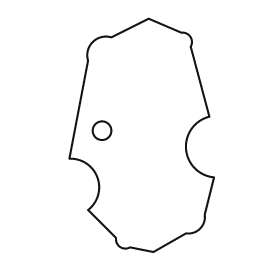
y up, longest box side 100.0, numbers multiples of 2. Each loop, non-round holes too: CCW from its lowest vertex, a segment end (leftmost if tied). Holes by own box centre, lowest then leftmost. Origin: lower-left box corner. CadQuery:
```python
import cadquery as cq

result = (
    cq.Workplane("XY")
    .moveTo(36.0, 0.0)
    .lineTo(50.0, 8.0)
    .threePointArc((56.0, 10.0), (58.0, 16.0))
    .lineTo(62.0, 32.0)
    .threePointArc((50.0, 44.0), (60.0, 58.0))
    .lineTo(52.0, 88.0)
    .threePointArc((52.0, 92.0), (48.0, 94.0))
    .lineTo(34.0, 100.0)
    .lineTo(18.0, 92.0)
    .threePointArc((10.0, 90.0), (8.0, 82.0))
    .lineTo(0.0, 40.0)
    .threePointArc((12.0, 32.0), (8.0, 18.0))
    .lineTo(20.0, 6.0)
    .threePointArc((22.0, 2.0), (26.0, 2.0))
    .close()
    .moveTo(14.0, 52.0)
    .circle(4.0)
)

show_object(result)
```